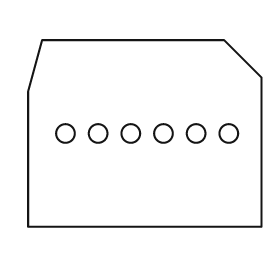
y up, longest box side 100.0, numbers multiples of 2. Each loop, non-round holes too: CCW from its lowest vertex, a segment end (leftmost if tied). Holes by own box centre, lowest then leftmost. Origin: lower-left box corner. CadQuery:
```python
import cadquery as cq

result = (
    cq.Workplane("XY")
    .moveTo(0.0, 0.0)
    .lineTo(100.0, 0.0)
    .lineTo(100.0, 64.0)
    .lineTo(84.0, 80.0)
    .lineTo(6.0, 80.0)
    .lineTo(0.0, 58.0)
    .close()
    .moveTo(16.0, 40.0)
    .circle(4.0)
    .moveTo(30.0, 40.0)
    .circle(4.0)
    .moveTo(44.0, 40.0)
    .circle(4.0)
    .moveTo(58.0, 40.0)
    .circle(4.0)
    .moveTo(72.0, 40.0)
    .circle(4.0)
    .moveTo(86.0, 40.0)
    .circle(4.0)
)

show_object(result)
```